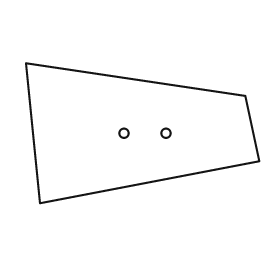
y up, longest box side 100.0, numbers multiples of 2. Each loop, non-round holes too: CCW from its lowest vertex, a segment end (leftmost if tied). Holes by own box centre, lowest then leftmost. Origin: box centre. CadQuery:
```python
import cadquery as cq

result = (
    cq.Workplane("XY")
    .moveTo(-44.0, -30.0)
    .lineTo(50.0, -12.0)
    .lineTo(44.0, 16.0)
    .lineTo(-50.0, 30.0)
    .close()
    .moveTo(-8.0, 0.0)
    .circle(2.0)
    .moveTo(10.0, 0.0)
    .circle(2.0)
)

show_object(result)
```